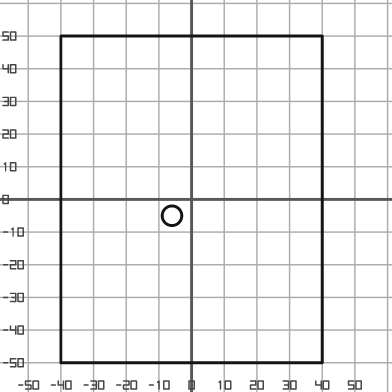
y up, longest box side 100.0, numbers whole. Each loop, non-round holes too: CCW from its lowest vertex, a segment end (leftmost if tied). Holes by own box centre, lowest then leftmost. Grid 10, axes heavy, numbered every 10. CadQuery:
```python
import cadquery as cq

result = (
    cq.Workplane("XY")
    .moveTo(-40.0, -50.0)
    .lineTo(40.0, -50.0)
    .lineTo(40.0, 50.0)
    .lineTo(-40.0, 50.0)
    .close()
    .moveTo(-6.0, -5.0)
    .circle(3.0)
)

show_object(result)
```